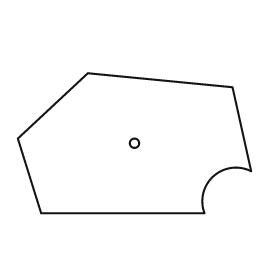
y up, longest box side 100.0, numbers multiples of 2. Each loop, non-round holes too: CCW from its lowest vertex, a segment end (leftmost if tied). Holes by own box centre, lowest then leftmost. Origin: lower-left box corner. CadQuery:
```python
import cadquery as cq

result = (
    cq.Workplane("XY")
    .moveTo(10.0, 0.0)
    .lineTo(80.0, 0.0)
    .threePointArc((84.0, 16.0), (100.0, 18.0))
    .lineTo(92.0, 54.0)
    .lineTo(30.0, 60.0)
    .lineTo(0.0, 32.0)
    .close()
    .moveTo(50.0, 30.0)
    .circle(2.0)
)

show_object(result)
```